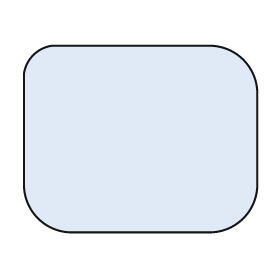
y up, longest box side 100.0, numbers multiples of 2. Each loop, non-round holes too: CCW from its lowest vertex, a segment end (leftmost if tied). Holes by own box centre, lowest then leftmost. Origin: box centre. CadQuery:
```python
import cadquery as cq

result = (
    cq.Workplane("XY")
    .moveTo(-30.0, -40.0)
    .lineTo(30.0, -40.0)
    .threePointArc((44.0, -34.0), (50.0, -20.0))
    .lineTo(50.0, 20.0)
    .threePointArc((44.0, 34.0), (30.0, 40.0))
    .lineTo(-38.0, 40.0)
    .threePointArc((-46.0, 36.0), (-50.0, 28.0))
    .lineTo(-50.0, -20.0)
    .threePointArc((-44.0, -34.0), (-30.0, -40.0))
    .close()
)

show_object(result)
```